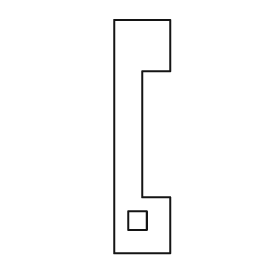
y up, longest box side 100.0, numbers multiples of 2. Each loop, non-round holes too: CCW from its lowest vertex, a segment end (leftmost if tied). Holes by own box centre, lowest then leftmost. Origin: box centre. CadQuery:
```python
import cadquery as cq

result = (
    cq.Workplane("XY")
    .moveTo(-12.0, -50.0)
    .lineTo(12.0, -50.0)
    .lineTo(12.0, -26.0)
    .lineTo(0.0, -26.0)
    .lineTo(0.0, 28.0)
    .lineTo(12.0, 28.0)
    .lineTo(12.0, 50.0)
    .lineTo(-12.0, 50.0)
    .close()
    .moveTo(-6.0, -40.0)
    .lineTo(2.0, -40.0)
    .lineTo(2.0, -32.0)
    .lineTo(-6.0, -32.0)
    .close()
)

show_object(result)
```